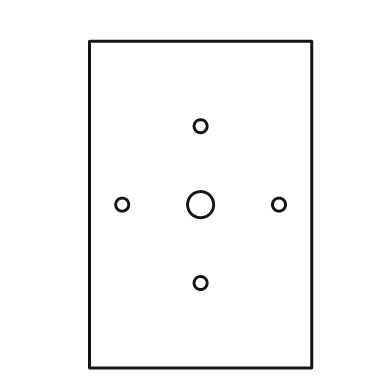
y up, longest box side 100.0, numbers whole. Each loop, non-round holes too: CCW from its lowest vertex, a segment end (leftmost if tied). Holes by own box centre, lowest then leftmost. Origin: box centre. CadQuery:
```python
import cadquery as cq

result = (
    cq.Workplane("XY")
    .moveTo(-34.0, -50.0)
    .lineTo(34.0, -50.0)
    .lineTo(34.0, 50.0)
    .lineTo(-34.0, 50.0)
    .close()
    .moveTo(0.0, -24.0)
    .circle(2.0)
    .moveTo(-24.0, 0.0)
    .circle(2.0)
    .moveTo(0.0, 0.0)
    .circle(4.0)
    .moveTo(24.0, 0.0)
    .circle(2.0)
    .moveTo(0.0, 24.0)
    .circle(2.0)
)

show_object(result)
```